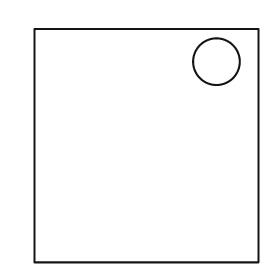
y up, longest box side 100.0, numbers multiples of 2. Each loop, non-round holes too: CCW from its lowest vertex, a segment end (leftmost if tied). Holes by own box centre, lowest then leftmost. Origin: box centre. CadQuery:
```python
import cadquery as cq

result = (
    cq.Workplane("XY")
    .moveTo(-48.0, -50.0)
    .lineTo(48.0, -50.0)
    .lineTo(48.0, 50.0)
    .lineTo(-48.0, 50.0)
    .close()
    .moveTo(30.0, 36.0)
    .circle(10.0)
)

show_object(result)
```